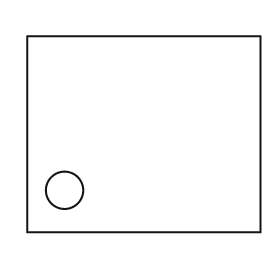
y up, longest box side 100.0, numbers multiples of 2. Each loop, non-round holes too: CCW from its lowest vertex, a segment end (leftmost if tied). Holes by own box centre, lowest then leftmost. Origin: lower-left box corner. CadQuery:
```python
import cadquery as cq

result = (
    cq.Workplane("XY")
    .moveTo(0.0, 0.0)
    .lineTo(100.0, 0.0)
    .lineTo(100.0, 84.0)
    .lineTo(0.0, 84.0)
    .close()
    .moveTo(16.0, 18.0)
    .circle(8.0)
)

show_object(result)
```